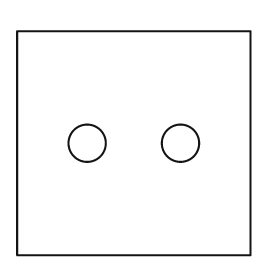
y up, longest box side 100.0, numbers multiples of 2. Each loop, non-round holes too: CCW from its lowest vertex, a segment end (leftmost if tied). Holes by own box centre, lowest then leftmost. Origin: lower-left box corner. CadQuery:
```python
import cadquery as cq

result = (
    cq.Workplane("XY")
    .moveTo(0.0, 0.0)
    .lineTo(100.0, 0.0)
    .lineTo(100.0, 96.0)
    .lineTo(0.0, 96.0)
    .close()
    .moveTo(30.0, 48.0)
    .circle(8.0)
    .moveTo(70.0, 48.0)
    .circle(8.0)
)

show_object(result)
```